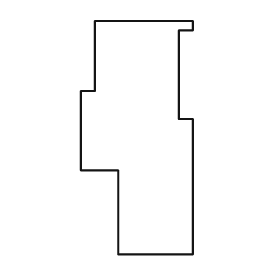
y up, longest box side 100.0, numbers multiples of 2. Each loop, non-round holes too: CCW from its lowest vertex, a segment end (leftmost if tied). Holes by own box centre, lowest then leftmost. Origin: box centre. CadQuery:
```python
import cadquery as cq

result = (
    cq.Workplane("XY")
    .moveTo(-8.0, -50.0)
    .lineTo(24.0, -50.0)
    .lineTo(24.0, 8.0)
    .lineTo(18.0, 8.0)
    .lineTo(18.0, 46.0)
    .lineTo(24.0, 46.0)
    .lineTo(24.0, 50.0)
    .lineTo(-18.0, 50.0)
    .lineTo(-18.0, 20.0)
    .lineTo(-24.0, 20.0)
    .lineTo(-24.0, -14.0)
    .lineTo(-8.0, -14.0)
    .close()
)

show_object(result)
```